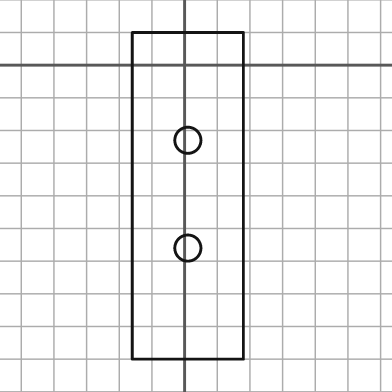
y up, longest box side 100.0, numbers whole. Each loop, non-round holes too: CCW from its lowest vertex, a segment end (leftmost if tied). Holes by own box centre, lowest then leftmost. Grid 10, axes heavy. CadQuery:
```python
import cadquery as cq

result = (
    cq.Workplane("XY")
    .moveTo(-16.0, -90.0)
    .lineTo(18.0, -90.0)
    .lineTo(18.0, 10.0)
    .lineTo(-16.0, 10.0)
    .close()
    .moveTo(1.0, -56.0)
    .circle(4.0)
    .moveTo(1.0, -23.0)
    .circle(4.0)
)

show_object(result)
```